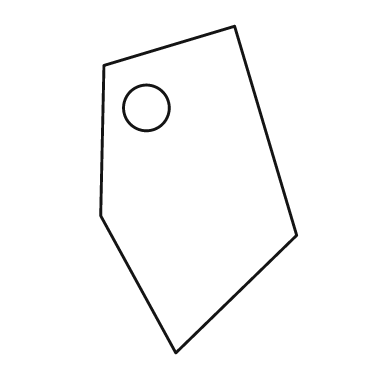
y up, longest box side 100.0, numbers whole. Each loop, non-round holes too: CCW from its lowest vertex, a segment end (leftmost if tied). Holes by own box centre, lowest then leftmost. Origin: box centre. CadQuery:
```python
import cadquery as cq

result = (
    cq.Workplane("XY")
    .moveTo(-7.0, -50.0)
    .lineTo(30.0, -14.0)
    .lineTo(11.0, 50.0)
    .lineTo(-29.0, 38.0)
    .lineTo(-30.0, -8.0)
    .close()
    .moveTo(-16.0, 25.0)
    .circle(7.0)
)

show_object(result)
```